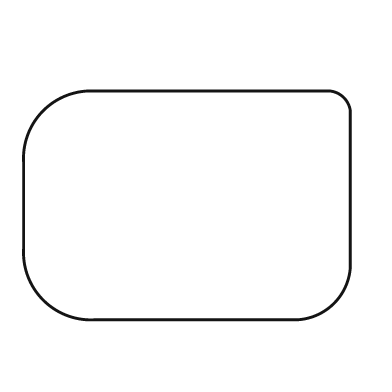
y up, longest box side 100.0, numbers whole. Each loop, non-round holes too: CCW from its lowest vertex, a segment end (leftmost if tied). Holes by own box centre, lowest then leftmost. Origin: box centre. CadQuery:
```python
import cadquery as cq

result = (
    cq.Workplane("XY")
    .moveTo(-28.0, -35.0)
    .lineTo(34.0, -35.0)
    .threePointArc((45.0, -30.0), (50.0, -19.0))
    .lineTo(50.0, 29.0)
    .threePointArc((48.0, 33.0), (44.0, 35.0))
    .lineTo(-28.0, 35.0)
    .threePointArc((-44.0, 29.0), (-50.0, 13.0))
    .lineTo(-50.0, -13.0)
    .threePointArc((-44.0, -29.0), (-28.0, -35.0))
    .close()
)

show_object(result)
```